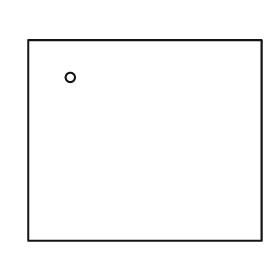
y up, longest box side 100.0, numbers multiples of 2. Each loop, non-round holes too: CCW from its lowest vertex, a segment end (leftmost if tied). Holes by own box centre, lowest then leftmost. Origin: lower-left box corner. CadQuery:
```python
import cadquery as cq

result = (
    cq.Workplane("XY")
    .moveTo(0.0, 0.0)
    .lineTo(100.0, 0.0)
    .lineTo(100.0, 86.0)
    .lineTo(0.0, 86.0)
    .close()
    .moveTo(18.0, 70.0)
    .circle(2.0)
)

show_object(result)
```